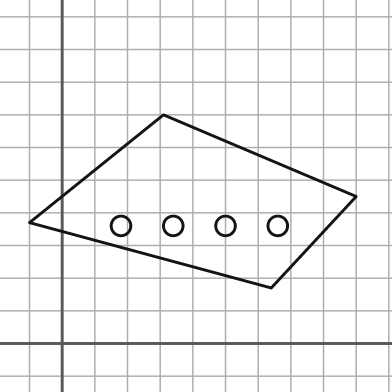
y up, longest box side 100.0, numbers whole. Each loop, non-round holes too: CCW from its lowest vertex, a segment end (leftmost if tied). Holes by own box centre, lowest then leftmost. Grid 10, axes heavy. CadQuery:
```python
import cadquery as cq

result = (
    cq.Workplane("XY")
    .moveTo(64.0, 17.0)
    .lineTo(90.0, 45.0)
    .lineTo(31.0, 70.0)
    .lineTo(-10.0, 37.0)
    .close()
    .moveTo(18.0, 36.0)
    .circle(3.0)
    .moveTo(34.0, 36.0)
    .circle(3.0)
    .moveTo(50.0, 36.0)
    .circle(3.0)
    .moveTo(66.0, 36.0)
    .circle(3.0)
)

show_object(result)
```